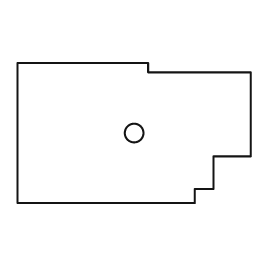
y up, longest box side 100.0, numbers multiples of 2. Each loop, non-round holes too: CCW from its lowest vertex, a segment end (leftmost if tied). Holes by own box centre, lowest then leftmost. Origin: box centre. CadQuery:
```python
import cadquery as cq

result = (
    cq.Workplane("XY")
    .moveTo(-50.0, -30.0)
    .lineTo(26.0, -30.0)
    .lineTo(26.0, -24.0)
    .lineTo(34.0, -24.0)
    .lineTo(34.0, -10.0)
    .lineTo(50.0, -10.0)
    .lineTo(50.0, 26.0)
    .lineTo(6.0, 26.0)
    .lineTo(6.0, 30.0)
    .lineTo(-50.0, 30.0)
    .close()
    .moveTo(0.0, 0.0)
    .circle(4.0)
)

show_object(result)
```